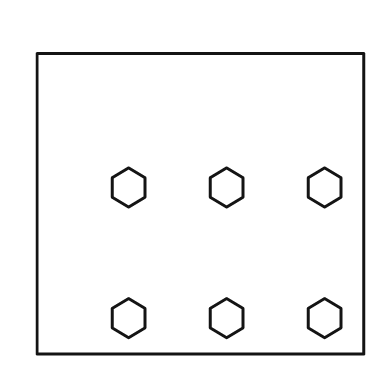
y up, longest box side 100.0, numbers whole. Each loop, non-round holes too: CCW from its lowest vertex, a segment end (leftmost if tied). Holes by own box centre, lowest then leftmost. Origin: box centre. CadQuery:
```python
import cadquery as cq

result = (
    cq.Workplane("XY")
    .moveTo(-50.0, -46.0)
    .lineTo(50.0, -46.0)
    .lineTo(50.0, 46.0)
    .lineTo(-50.0, 46.0)
    .close()
    .moveTo(-22.0, -41.0)
    .lineTo(-17.0, -38.0)
    .lineTo(-17.0, -32.0)
    .lineTo(-22.0, -29.0)
    .lineTo(-27.0, -32.0)
    .lineTo(-27.0, -38.0)
    .close()
    .moveTo(8.0, -41.0)
    .lineTo(13.0, -38.0)
    .lineTo(13.0, -32.0)
    .lineTo(8.0, -29.0)
    .lineTo(3.0, -32.0)
    .lineTo(3.0, -38.0)
    .close()
    .moveTo(38.0, -41.0)
    .lineTo(43.0, -38.0)
    .lineTo(43.0, -32.0)
    .lineTo(38.0, -29.0)
    .lineTo(33.0, -32.0)
    .lineTo(33.0, -38.0)
    .close()
    .moveTo(-22.0, -1.0)
    .lineTo(-17.0, 2.0)
    .lineTo(-17.0, 8.0)
    .lineTo(-22.0, 11.0)
    .lineTo(-27.0, 8.0)
    .lineTo(-27.0, 2.0)
    .close()
    .moveTo(8.0, -1.0)
    .lineTo(13.0, 2.0)
    .lineTo(13.0, 8.0)
    .lineTo(8.0, 11.0)
    .lineTo(3.0, 8.0)
    .lineTo(3.0, 2.0)
    .close()
    .moveTo(38.0, -1.0)
    .lineTo(43.0, 2.0)
    .lineTo(43.0, 8.0)
    .lineTo(38.0, 11.0)
    .lineTo(33.0, 8.0)
    .lineTo(33.0, 2.0)
    .close()
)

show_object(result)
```